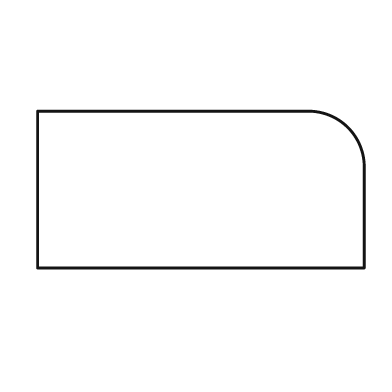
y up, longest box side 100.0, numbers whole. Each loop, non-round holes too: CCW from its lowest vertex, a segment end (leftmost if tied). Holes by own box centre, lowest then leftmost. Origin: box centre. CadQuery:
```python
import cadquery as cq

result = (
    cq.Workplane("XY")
    .moveTo(-50.0, -24.0)
    .lineTo(50.0, -24.0)
    .lineTo(50.0, 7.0)
    .threePointArc((45.0, 19.0), (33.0, 24.0))
    .lineTo(-50.0, 24.0)
    .close()
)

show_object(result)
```